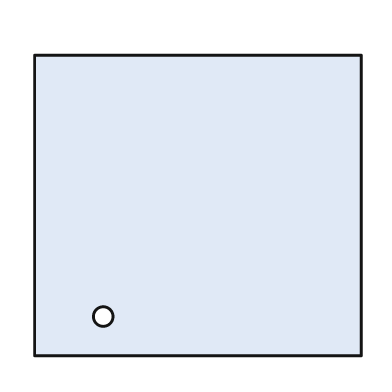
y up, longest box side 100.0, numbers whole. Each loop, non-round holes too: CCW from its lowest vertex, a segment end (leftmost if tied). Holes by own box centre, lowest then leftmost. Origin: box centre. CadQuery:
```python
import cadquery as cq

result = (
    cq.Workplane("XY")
    .moveTo(-50.0, -46.0)
    .lineTo(50.0, -46.0)
    .lineTo(50.0, 46.0)
    .lineTo(-50.0, 46.0)
    .close()
    .moveTo(-29.0, -34.0)
    .circle(3.0)
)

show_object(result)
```